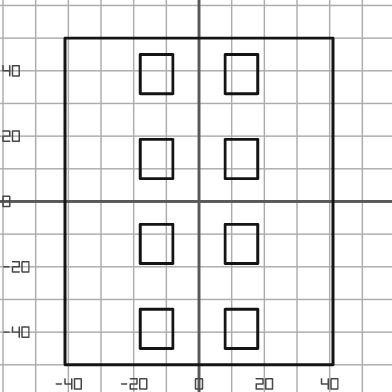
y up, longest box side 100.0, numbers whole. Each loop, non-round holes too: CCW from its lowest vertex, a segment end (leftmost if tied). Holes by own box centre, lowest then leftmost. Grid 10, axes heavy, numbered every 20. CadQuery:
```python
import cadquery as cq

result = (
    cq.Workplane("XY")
    .moveTo(-41.0, -50.0)
    .lineTo(41.0, -50.0)
    .lineTo(41.0, 50.0)
    .lineTo(-41.0, 50.0)
    .close()
    .moveTo(-18.0, -45.0)
    .lineTo(-8.0, -45.0)
    .lineTo(-8.0, -33.0)
    .lineTo(-18.0, -33.0)
    .close()
    .moveTo(8.0, -45.0)
    .lineTo(18.0, -45.0)
    .lineTo(18.0, -33.0)
    .lineTo(8.0, -33.0)
    .close()
    .moveTo(-18.0, -19.0)
    .lineTo(-8.0, -19.0)
    .lineTo(-8.0, -7.0)
    .lineTo(-18.0, -7.0)
    .close()
    .moveTo(8.0, -19.0)
    .lineTo(18.0, -19.0)
    .lineTo(18.0, -7.0)
    .lineTo(8.0, -7.0)
    .close()
    .moveTo(-18.0, 7.0)
    .lineTo(-8.0, 7.0)
    .lineTo(-8.0, 19.0)
    .lineTo(-18.0, 19.0)
    .close()
    .moveTo(8.0, 7.0)
    .lineTo(18.0, 7.0)
    .lineTo(18.0, 19.0)
    .lineTo(8.0, 19.0)
    .close()
    .moveTo(-18.0, 33.0)
    .lineTo(-8.0, 33.0)
    .lineTo(-8.0, 45.0)
    .lineTo(-18.0, 45.0)
    .close()
    .moveTo(8.0, 33.0)
    .lineTo(18.0, 33.0)
    .lineTo(18.0, 45.0)
    .lineTo(8.0, 45.0)
    .close()
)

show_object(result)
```